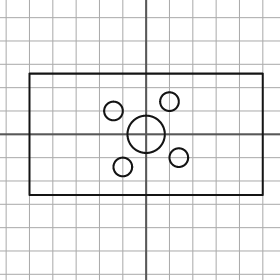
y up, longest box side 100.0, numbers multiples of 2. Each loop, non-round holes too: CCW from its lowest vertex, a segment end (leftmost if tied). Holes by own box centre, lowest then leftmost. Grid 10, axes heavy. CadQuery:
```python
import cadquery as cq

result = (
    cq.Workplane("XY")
    .moveTo(-50.0, -26.0)
    .lineTo(50.0, -26.0)
    .lineTo(50.0, 26.0)
    .lineTo(-50.0, 26.0)
    .close()
    .moveTo(-10.0, -14.0)
    .circle(4.0)
    .moveTo(14.0, -10.0)
    .circle(4.0)
    .moveTo(0.0, 0.0)
    .circle(8.0)
    .moveTo(-14.0, 10.0)
    .circle(4.0)
    .moveTo(10.0, 14.0)
    .circle(4.0)
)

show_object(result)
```